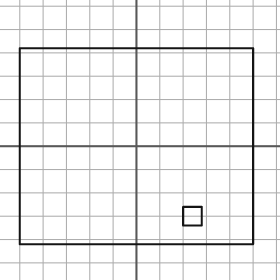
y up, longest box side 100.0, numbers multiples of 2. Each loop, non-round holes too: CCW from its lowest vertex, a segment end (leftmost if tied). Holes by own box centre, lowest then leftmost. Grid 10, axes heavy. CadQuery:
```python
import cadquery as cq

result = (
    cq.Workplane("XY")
    .moveTo(-50.0, -42.0)
    .lineTo(50.0, -42.0)
    .lineTo(50.0, 42.0)
    .lineTo(-50.0, 42.0)
    .close()
    .moveTo(20.0, -34.0)
    .lineTo(28.0, -34.0)
    .lineTo(28.0, -26.0)
    .lineTo(20.0, -26.0)
    .close()
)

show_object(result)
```